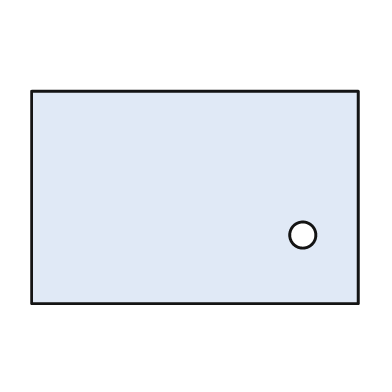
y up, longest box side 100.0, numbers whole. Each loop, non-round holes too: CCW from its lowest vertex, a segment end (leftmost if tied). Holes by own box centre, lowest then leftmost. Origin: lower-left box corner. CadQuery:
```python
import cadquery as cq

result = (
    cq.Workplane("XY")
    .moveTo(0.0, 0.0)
    .lineTo(100.0, 0.0)
    .lineTo(100.0, 65.0)
    .lineTo(0.0, 65.0)
    .close()
    .moveTo(83.0, 21.0)
    .circle(4.0)
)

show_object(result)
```